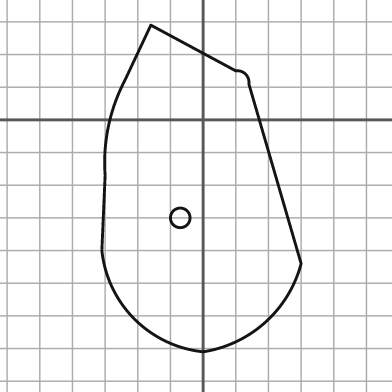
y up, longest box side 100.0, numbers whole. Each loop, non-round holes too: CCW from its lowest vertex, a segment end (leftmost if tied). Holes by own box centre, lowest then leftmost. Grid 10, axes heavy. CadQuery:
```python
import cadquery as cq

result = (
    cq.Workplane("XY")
    .moveTo(0.0, -71.0)
    .threePointArc((19.0, -62.0), (30.0, -44.0))
    .lineTo(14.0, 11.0)
    .threePointArc((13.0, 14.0), (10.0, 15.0))
    .lineTo(-16.0, 29.0)
    .lineTo(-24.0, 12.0)
    .threePointArc((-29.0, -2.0), (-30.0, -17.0))
    .lineTo(-31.0, -40.0)
    .threePointArc((-21.0, -61.0), (0.0, -71.0))
    .close()
    .moveTo(-7.0, -30.0)
    .circle(3.0)
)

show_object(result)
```